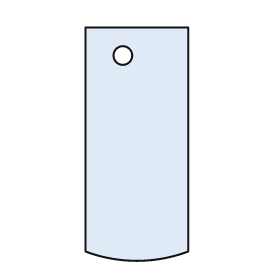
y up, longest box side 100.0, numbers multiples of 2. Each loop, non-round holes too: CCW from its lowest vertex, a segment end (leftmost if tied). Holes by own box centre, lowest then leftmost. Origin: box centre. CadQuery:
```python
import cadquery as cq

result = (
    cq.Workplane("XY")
    .moveTo(-22.0, -46.0)
    .threePointArc((0.0, -50.0), (22.0, -46.0))
    .lineTo(22.0, 50.0)
    .lineTo(-22.0, 50.0)
    .close()
    .moveTo(-6.0, 38.0)
    .circle(4.0)
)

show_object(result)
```